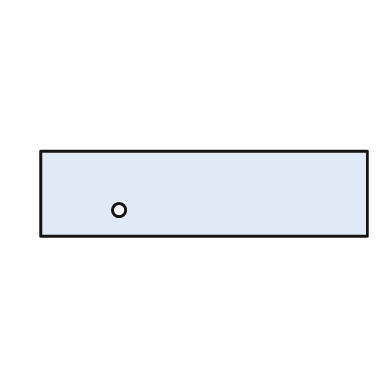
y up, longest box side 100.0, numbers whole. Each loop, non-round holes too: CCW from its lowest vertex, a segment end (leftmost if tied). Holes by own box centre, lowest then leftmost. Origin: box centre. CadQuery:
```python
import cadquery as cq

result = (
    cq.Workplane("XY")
    .moveTo(-50.0, -13.0)
    .lineTo(50.0, -13.0)
    .lineTo(50.0, 13.0)
    .lineTo(-50.0, 13.0)
    .close()
    .moveTo(-26.0, -5.0)
    .circle(2.0)
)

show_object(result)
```